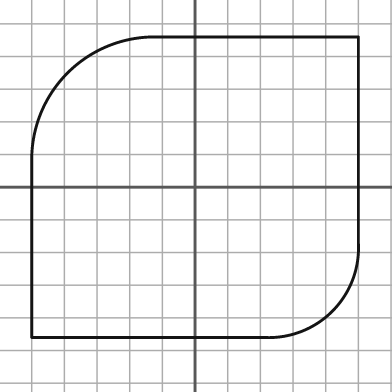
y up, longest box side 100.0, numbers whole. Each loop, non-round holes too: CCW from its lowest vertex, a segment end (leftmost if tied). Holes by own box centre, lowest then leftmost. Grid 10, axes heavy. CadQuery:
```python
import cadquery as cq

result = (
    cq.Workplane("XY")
    .moveTo(-50.0, -46.0)
    .lineTo(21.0, -46.0)
    .threePointArc((42.0, -38.0), (50.0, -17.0))
    .lineTo(50.0, 46.0)
    .lineTo(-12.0, 46.0)
    .threePointArc((-39.0, 35.0), (-50.0, 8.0))
    .close()
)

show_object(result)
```